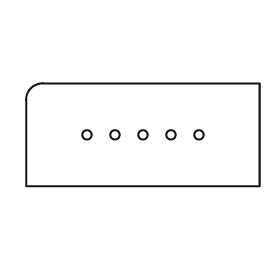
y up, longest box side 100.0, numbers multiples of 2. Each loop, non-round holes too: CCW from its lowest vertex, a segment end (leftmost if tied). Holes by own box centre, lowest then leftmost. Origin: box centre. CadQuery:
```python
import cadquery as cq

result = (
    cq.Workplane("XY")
    .moveTo(-50.0, -22.0)
    .lineTo(50.0, -22.0)
    .lineTo(50.0, 22.0)
    .lineTo(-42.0, 22.0)
    .threePointArc((-48.0, 20.0), (-50.0, 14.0))
    .close()
    .moveTo(-24.0, 0.0)
    .circle(2.0)
    .moveTo(-12.0, 0.0)
    .circle(2.0)
    .moveTo(0.0, 0.0)
    .circle(2.0)
    .moveTo(12.0, 0.0)
    .circle(2.0)
    .moveTo(24.0, 0.0)
    .circle(2.0)
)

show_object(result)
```